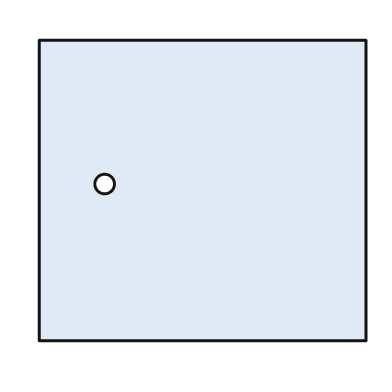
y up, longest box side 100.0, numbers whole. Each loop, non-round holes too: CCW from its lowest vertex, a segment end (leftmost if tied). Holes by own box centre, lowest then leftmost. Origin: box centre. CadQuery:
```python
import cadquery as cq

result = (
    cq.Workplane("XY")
    .moveTo(-50.0, -46.0)
    .lineTo(50.0, -46.0)
    .lineTo(50.0, 46.0)
    .lineTo(-50.0, 46.0)
    .close()
    .moveTo(-30.0, 2.0)
    .circle(3.0)
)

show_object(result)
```